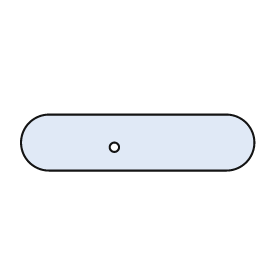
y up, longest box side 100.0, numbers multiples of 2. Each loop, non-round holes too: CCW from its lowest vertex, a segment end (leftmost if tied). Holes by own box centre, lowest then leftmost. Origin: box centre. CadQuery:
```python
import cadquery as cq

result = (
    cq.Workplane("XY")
    .moveTo(-38.0, -12.0)
    .lineTo(38.0, -12.0)
    .threePointArc((50.0, 0.0), (38.0, 12.0))
    .lineTo(-38.0, 12.0)
    .threePointArc((-50.0, 0.0), (-38.0, -12.0))
    .close()
    .moveTo(-10.0, -2.0)
    .circle(2.0)
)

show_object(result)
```